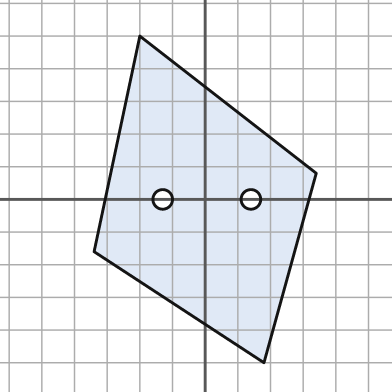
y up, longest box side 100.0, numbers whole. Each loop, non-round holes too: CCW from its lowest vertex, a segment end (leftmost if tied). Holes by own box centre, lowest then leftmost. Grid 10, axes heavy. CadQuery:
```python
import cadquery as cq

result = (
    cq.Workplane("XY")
    .moveTo(18.0, -50.0)
    .lineTo(34.0, 8.0)
    .lineTo(-20.0, 50.0)
    .lineTo(-34.0, -16.0)
    .close()
    .moveTo(-13.0, 0.0)
    .circle(3.0)
    .moveTo(14.0, 0.0)
    .circle(3.0)
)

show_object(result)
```